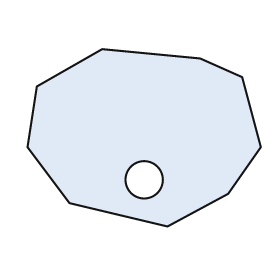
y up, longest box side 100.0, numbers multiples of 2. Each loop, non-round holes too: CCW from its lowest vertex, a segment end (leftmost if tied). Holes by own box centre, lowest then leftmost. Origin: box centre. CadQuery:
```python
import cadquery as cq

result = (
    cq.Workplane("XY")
    .moveTo(10.0, -38.0)
    .lineTo(36.0, -24.0)
    .lineTo(50.0, -4.0)
    .lineTo(42.0, 26.0)
    .lineTo(24.0, 34.0)
    .lineTo(-18.0, 38.0)
    .lineTo(-46.0, 22.0)
    .lineTo(-50.0, -4.0)
    .lineTo(-32.0, -28.0)
    .close()
    .moveTo(0.0, -18.0)
    .circle(8.0)
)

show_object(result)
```